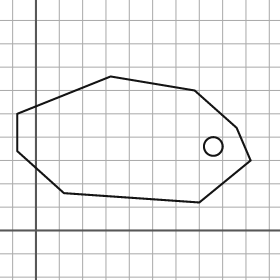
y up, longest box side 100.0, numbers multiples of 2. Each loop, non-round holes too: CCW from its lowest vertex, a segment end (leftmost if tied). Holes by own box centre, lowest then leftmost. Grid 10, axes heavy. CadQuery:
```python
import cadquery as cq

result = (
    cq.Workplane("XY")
    .moveTo(70.0, 12.0)
    .lineTo(92.0, 30.0)
    .lineTo(86.0, 44.0)
    .lineTo(68.0, 60.0)
    .lineTo(32.0, 66.0)
    .lineTo(-8.0, 50.0)
    .lineTo(-8.0, 34.0)
    .lineTo(12.0, 16.0)
    .close()
    .moveTo(76.0, 36.0)
    .circle(4.0)
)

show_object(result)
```